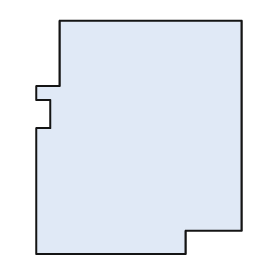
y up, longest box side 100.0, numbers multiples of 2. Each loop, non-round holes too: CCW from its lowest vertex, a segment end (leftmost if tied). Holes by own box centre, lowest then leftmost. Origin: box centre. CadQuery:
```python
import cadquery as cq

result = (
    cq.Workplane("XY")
    .moveTo(-44.0, -50.0)
    .lineTo(20.0, -50.0)
    .lineTo(20.0, -40.0)
    .lineTo(44.0, -40.0)
    .lineTo(44.0, 50.0)
    .lineTo(-34.0, 50.0)
    .lineTo(-34.0, 22.0)
    .lineTo(-44.0, 22.0)
    .lineTo(-44.0, 16.0)
    .lineTo(-38.0, 16.0)
    .lineTo(-38.0, 4.0)
    .lineTo(-44.0, 4.0)
    .close()
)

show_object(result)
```